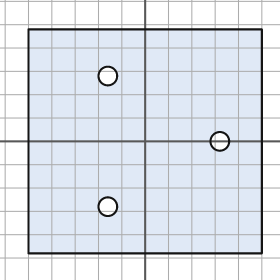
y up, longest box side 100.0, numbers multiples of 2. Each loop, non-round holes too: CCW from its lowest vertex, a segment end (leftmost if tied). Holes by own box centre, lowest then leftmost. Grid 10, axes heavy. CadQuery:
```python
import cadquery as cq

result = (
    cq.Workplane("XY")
    .moveTo(-50.0, -48.0)
    .lineTo(50.0, -48.0)
    .lineTo(50.0, 48.0)
    .lineTo(-50.0, 48.0)
    .close()
    .moveTo(-16.0, -28.0)
    .circle(4.0)
    .moveTo(32.0, 0.0)
    .circle(4.0)
    .moveTo(-16.0, 28.0)
    .circle(4.0)
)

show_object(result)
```